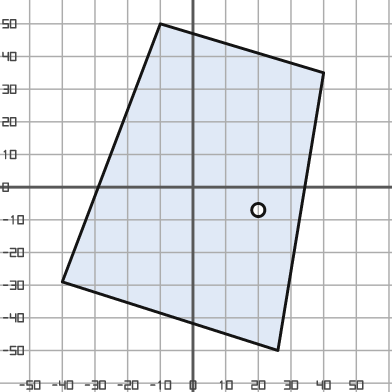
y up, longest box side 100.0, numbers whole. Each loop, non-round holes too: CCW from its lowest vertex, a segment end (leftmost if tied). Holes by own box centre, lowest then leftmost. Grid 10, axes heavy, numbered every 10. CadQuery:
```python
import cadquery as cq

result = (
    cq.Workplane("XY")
    .moveTo(26.0, -50.0)
    .lineTo(40.0, 35.0)
    .lineTo(-10.0, 50.0)
    .lineTo(-40.0, -29.0)
    .close()
    .moveTo(20.0, -7.0)
    .circle(2.0)
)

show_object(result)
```